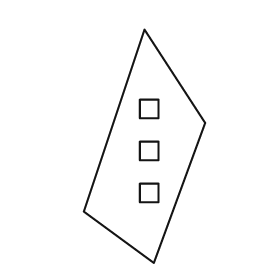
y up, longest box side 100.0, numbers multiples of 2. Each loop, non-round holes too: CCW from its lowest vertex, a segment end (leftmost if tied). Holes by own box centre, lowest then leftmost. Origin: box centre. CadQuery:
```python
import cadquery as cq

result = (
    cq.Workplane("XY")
    .moveTo(4.0, -50.0)
    .lineTo(26.0, 10.0)
    .lineTo(0.0, 50.0)
    .lineTo(-26.0, -28.0)
    .close()
    .moveTo(-2.0, -24.0)
    .lineTo(6.0, -24.0)
    .lineTo(6.0, -16.0)
    .lineTo(-2.0, -16.0)
    .close()
    .moveTo(-2.0, -6.0)
    .lineTo(6.0, -6.0)
    .lineTo(6.0, 2.0)
    .lineTo(-2.0, 2.0)
    .close()
    .moveTo(-2.0, 12.0)
    .lineTo(6.0, 12.0)
    .lineTo(6.0, 20.0)
    .lineTo(-2.0, 20.0)
    .close()
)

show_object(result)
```